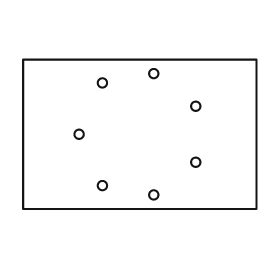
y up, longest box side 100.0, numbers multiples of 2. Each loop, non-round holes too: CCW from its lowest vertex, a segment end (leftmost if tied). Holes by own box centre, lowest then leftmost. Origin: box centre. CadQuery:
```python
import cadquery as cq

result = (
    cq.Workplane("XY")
    .moveTo(-50.0, -32.0)
    .lineTo(50.0, -32.0)
    .lineTo(50.0, 32.0)
    .lineTo(-50.0, 32.0)
    .close()
    .moveTo(6.0, -26.0)
    .circle(2.0)
    .moveTo(-16.0, -22.0)
    .circle(2.0)
    .moveTo(24.0, -12.0)
    .circle(2.0)
    .moveTo(-26.0, 0.0)
    .circle(2.0)
    .moveTo(24.0, 12.0)
    .circle(2.0)
    .moveTo(-16.0, 22.0)
    .circle(2.0)
    .moveTo(6.0, 26.0)
    .circle(2.0)
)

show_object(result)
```